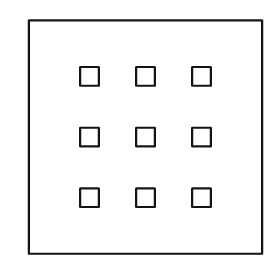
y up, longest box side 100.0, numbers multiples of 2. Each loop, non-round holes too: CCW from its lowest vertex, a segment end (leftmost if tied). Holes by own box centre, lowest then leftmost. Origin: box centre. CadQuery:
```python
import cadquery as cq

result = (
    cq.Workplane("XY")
    .moveTo(-50.0, -50.0)
    .lineTo(50.0, -50.0)
    .lineTo(50.0, 50.0)
    .lineTo(-50.0, 50.0)
    .close()
    .moveTo(-28.0, -30.0)
    .lineTo(-20.0, -30.0)
    .lineTo(-20.0, -22.0)
    .lineTo(-28.0, -22.0)
    .close()
    .moveTo(-4.0, -30.0)
    .lineTo(4.0, -30.0)
    .lineTo(4.0, -22.0)
    .lineTo(-4.0, -22.0)
    .close()
    .moveTo(20.0, -30.0)
    .lineTo(28.0, -30.0)
    .lineTo(28.0, -22.0)
    .lineTo(20.0, -22.0)
    .close()
    .moveTo(-28.0, -4.0)
    .lineTo(-20.0, -4.0)
    .lineTo(-20.0, 4.0)
    .lineTo(-28.0, 4.0)
    .close()
    .moveTo(-4.0, -4.0)
    .lineTo(4.0, -4.0)
    .lineTo(4.0, 4.0)
    .lineTo(-4.0, 4.0)
    .close()
    .moveTo(20.0, -4.0)
    .lineTo(28.0, -4.0)
    .lineTo(28.0, 4.0)
    .lineTo(20.0, 4.0)
    .close()
    .moveTo(-28.0, 22.0)
    .lineTo(-20.0, 22.0)
    .lineTo(-20.0, 30.0)
    .lineTo(-28.0, 30.0)
    .close()
    .moveTo(-4.0, 22.0)
    .lineTo(4.0, 22.0)
    .lineTo(4.0, 30.0)
    .lineTo(-4.0, 30.0)
    .close()
    .moveTo(20.0, 22.0)
    .lineTo(28.0, 22.0)
    .lineTo(28.0, 30.0)
    .lineTo(20.0, 30.0)
    .close()
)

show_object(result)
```